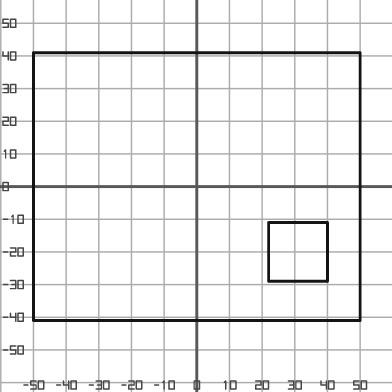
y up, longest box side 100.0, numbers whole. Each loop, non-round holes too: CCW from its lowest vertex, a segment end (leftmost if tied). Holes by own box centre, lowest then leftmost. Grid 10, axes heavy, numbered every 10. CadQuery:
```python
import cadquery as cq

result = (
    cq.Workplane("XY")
    .moveTo(-50.0, -41.0)
    .lineTo(50.0, -41.0)
    .lineTo(50.0, 41.0)
    .lineTo(-50.0, 41.0)
    .close()
    .moveTo(22.0, -29.0)
    .lineTo(40.0, -29.0)
    .lineTo(40.0, -11.0)
    .lineTo(22.0, -11.0)
    .close()
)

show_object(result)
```